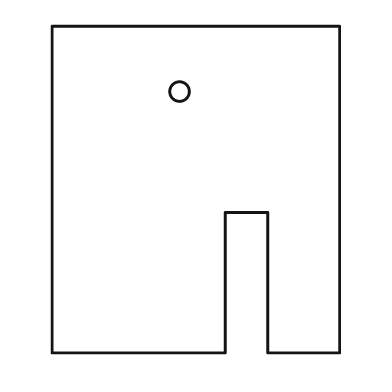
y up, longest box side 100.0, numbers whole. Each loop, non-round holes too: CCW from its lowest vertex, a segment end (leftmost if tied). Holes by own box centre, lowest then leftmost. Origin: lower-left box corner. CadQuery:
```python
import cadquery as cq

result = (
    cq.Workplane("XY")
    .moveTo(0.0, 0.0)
    .lineTo(53.0, 0.0)
    .lineTo(53.0, 43.0)
    .lineTo(66.0, 43.0)
    .lineTo(66.0, 0.0)
    .lineTo(88.0, 0.0)
    .lineTo(88.0, 100.0)
    .lineTo(0.0, 100.0)
    .close()
    .moveTo(39.0, 80.0)
    .circle(3.0)
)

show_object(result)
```